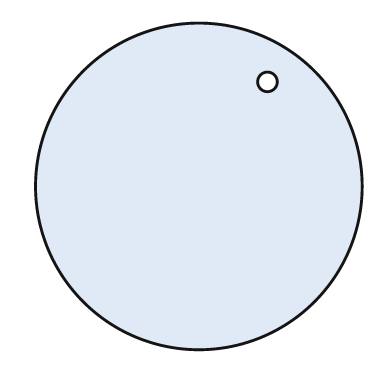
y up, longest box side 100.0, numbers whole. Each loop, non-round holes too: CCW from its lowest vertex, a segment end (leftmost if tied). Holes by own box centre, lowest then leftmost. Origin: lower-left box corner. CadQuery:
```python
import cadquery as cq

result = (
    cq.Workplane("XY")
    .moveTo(50.0, 50.0)
    .circle(50.0)
    .moveTo(71.0, 82.0)
    .circle(3.0)
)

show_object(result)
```